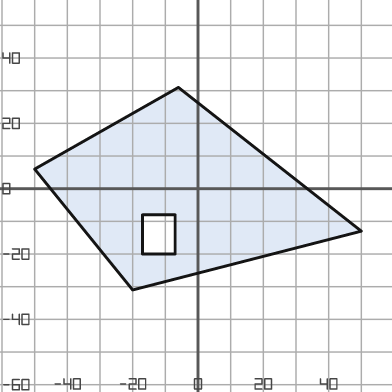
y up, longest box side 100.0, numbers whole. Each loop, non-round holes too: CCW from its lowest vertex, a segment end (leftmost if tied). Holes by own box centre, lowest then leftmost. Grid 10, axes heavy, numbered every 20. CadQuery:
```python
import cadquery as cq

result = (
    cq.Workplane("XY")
    .moveTo(-20.0, -31.0)
    .lineTo(50.0, -13.0)
    .lineTo(-6.0, 31.0)
    .lineTo(-50.0, 6.0)
    .close()
    .moveTo(-17.0, -20.0)
    .lineTo(-7.0, -20.0)
    .lineTo(-7.0, -8.0)
    .lineTo(-17.0, -8.0)
    .close()
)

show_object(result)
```